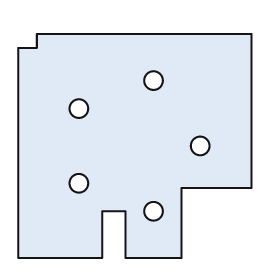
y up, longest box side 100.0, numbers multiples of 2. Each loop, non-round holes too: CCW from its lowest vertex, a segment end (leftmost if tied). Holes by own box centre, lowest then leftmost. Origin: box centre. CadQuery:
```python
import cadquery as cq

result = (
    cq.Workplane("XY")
    .moveTo(-50.0, -48.0)
    .lineTo(-14.0, -48.0)
    .lineTo(-14.0, -28.0)
    .lineTo(-4.0, -28.0)
    .lineTo(-4.0, -48.0)
    .lineTo(20.0, -48.0)
    .lineTo(20.0, -18.0)
    .lineTo(50.0, -18.0)
    .lineTo(50.0, 48.0)
    .lineTo(-42.0, 48.0)
    .lineTo(-42.0, 42.0)
    .lineTo(-50.0, 42.0)
    .close()
    .moveTo(8.0, -28.0)
    .circle(4.0)
    .moveTo(-24.0, -16.0)
    .circle(4.0)
    .moveTo(28.0, 0.0)
    .circle(4.0)
    .moveTo(-24.0, 16.0)
    .circle(4.0)
    .moveTo(8.0, 28.0)
    .circle(4.0)
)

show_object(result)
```